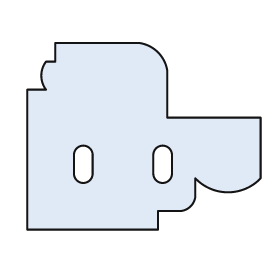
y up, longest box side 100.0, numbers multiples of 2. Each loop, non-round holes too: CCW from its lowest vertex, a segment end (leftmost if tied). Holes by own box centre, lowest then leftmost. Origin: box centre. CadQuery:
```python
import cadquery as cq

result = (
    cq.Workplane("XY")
    .moveTo(-50.0, -40.0)
    .lineTo(6.0, -40.0)
    .lineTo(6.0, -32.0)
    .lineTo(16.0, -32.0)
    .threePointArc((20.0, -30.0), (22.0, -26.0))
    .lineTo(22.0, -18.0)
    .threePointArc((36.0, -24.0), (50.0, -18.0))
    .lineTo(50.0, 8.0)
    .lineTo(10.0, 8.0)
    .lineTo(10.0, 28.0)
    .threePointArc((6.0, 36.0), (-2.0, 40.0))
    .lineTo(-38.0, 40.0)
    .lineTo(-38.0, 32.0)
    .lineTo(-42.0, 32.0)
    .threePointArc((-44.0, 26.0), (-42.0, 20.0))
    .lineTo(-50.0, 20.0)
    .close()
    .moveTo(-30.0, -16.0)
    .threePointArc((-26.0, -20.0), (-22.0, -16.0))
    .lineTo(-22.0, -8.0)
    .threePointArc((-26.0, -4.0), (-30.0, -8.0))
    .close()
    .moveTo(4.0, -16.0)
    .threePointArc((8.0, -20.0), (12.0, -16.0))
    .lineTo(12.0, -8.0)
    .threePointArc((8.0, -4.0), (4.0, -8.0))
    .close()
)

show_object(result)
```